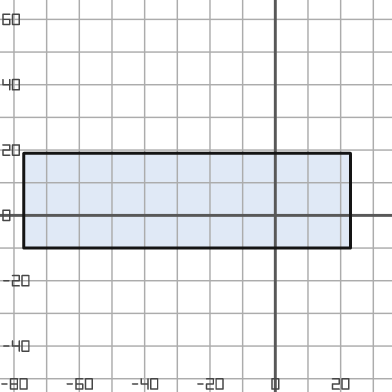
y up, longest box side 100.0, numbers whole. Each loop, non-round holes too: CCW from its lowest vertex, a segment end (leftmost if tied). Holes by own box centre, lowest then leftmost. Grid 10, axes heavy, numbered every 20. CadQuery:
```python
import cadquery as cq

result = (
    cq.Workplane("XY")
    .moveTo(-77.0, -10.0)
    .lineTo(23.0, -10.0)
    .lineTo(23.0, 19.0)
    .lineTo(-77.0, 19.0)
    .close()
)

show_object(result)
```